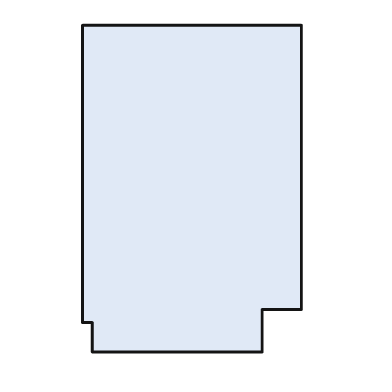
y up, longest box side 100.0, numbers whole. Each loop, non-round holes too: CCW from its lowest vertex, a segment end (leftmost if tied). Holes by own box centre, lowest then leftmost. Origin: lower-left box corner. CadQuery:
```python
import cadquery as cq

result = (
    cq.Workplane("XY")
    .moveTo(3.0, 0.0)
    .lineTo(55.0, 0.0)
    .lineTo(55.0, 13.0)
    .lineTo(67.0, 13.0)
    .lineTo(67.0, 100.0)
    .lineTo(0.0, 100.0)
    .lineTo(0.0, 9.0)
    .lineTo(3.0, 9.0)
    .close()
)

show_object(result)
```